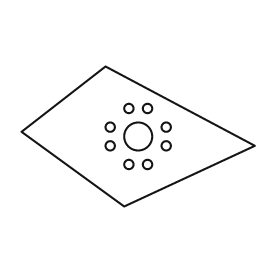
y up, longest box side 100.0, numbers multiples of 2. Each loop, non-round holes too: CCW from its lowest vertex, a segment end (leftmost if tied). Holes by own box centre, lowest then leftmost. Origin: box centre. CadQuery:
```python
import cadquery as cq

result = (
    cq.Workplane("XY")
    .moveTo(-6.0, -30.0)
    .lineTo(50.0, -4.0)
    .lineTo(-14.0, 30.0)
    .lineTo(-50.0, 2.0)
    .close()
    .moveTo(-4.0, -12.0)
    .circle(2.0)
    .moveTo(4.0, -12.0)
    .circle(2.0)
    .moveTo(-12.0, -4.0)
    .circle(2.0)
    .moveTo(12.0, -4.0)
    .circle(2.0)
    .moveTo(0.0, 0.0)
    .circle(6.0)
    .moveTo(-12.0, 4.0)
    .circle(2.0)
    .moveTo(12.0, 4.0)
    .circle(2.0)
    .moveTo(-4.0, 12.0)
    .circle(2.0)
    .moveTo(4.0, 12.0)
    .circle(2.0)
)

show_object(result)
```